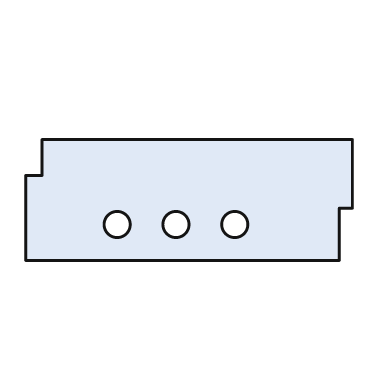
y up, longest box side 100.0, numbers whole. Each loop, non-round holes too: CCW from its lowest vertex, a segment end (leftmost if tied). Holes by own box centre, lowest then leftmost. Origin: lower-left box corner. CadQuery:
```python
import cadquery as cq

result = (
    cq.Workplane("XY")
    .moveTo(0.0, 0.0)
    .lineTo(96.0, 0.0)
    .lineTo(96.0, 16.0)
    .lineTo(100.0, 16.0)
    .lineTo(100.0, 37.0)
    .lineTo(5.0, 37.0)
    .lineTo(5.0, 26.0)
    .lineTo(0.0, 26.0)
    .close()
    .moveTo(28.0, 11.0)
    .circle(4.0)
    .moveTo(46.0, 11.0)
    .circle(4.0)
    .moveTo(64.0, 11.0)
    .circle(4.0)
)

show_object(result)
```